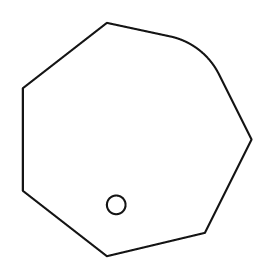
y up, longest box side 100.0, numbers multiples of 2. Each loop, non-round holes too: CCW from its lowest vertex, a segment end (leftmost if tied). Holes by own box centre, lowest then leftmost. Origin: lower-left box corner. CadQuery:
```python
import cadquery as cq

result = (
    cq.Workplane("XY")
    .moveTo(36.0, 0.0)
    .lineTo(78.0, 10.0)
    .lineTo(98.0, 50.0)
    .lineTo(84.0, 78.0)
    .threePointArc((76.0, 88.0), (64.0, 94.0))
    .lineTo(36.0, 100.0)
    .lineTo(0.0, 72.0)
    .lineTo(0.0, 28.0)
    .close()
    .moveTo(40.0, 22.0)
    .circle(4.0)
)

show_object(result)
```